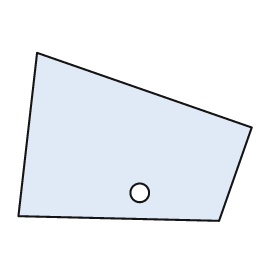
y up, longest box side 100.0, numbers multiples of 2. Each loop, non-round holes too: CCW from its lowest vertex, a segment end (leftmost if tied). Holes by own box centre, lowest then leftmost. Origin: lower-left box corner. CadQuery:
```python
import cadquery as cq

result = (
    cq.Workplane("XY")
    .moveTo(86.0, 0.0)
    .lineTo(100.0, 40.0)
    .lineTo(8.0, 72.0)
    .lineTo(0.0, 2.0)
    .close()
    .moveTo(52.0, 12.0)
    .circle(4.0)
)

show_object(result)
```